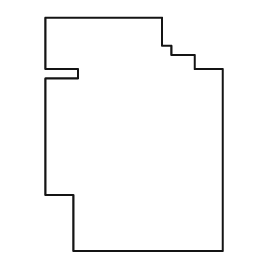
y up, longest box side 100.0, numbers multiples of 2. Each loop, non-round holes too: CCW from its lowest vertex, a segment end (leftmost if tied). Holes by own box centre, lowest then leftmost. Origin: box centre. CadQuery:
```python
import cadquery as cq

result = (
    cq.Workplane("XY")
    .moveTo(-26.0, -50.0)
    .lineTo(38.0, -50.0)
    .lineTo(38.0, 28.0)
    .lineTo(26.0, 28.0)
    .lineTo(26.0, 34.0)
    .lineTo(16.0, 34.0)
    .lineTo(16.0, 38.0)
    .lineTo(12.0, 38.0)
    .lineTo(12.0, 50.0)
    .lineTo(-38.0, 50.0)
    .lineTo(-38.0, 28.0)
    .lineTo(-24.0, 28.0)
    .lineTo(-24.0, 24.0)
    .lineTo(-38.0, 24.0)
    .lineTo(-38.0, -26.0)
    .lineTo(-26.0, -26.0)
    .close()
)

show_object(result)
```